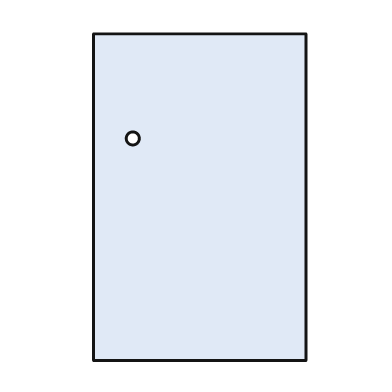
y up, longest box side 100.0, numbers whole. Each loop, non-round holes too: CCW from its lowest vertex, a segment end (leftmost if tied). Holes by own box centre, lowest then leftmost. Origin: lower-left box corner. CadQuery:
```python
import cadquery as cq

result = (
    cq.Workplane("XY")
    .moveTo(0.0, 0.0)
    .lineTo(65.0, 0.0)
    .lineTo(65.0, 100.0)
    .lineTo(0.0, 100.0)
    .close()
    .moveTo(12.0, 68.0)
    .circle(2.0)
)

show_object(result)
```